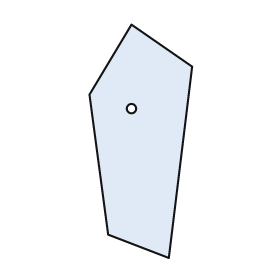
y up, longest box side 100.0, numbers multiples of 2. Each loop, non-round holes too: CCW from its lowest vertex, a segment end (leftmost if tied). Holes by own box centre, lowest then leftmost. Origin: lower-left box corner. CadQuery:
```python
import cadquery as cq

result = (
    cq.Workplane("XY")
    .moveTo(34.0, 0.0)
    .lineTo(44.0, 82.0)
    .lineTo(18.0, 100.0)
    .lineTo(0.0, 70.0)
    .lineTo(8.0, 10.0)
    .close()
    .moveTo(18.0, 64.0)
    .circle(2.0)
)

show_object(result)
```